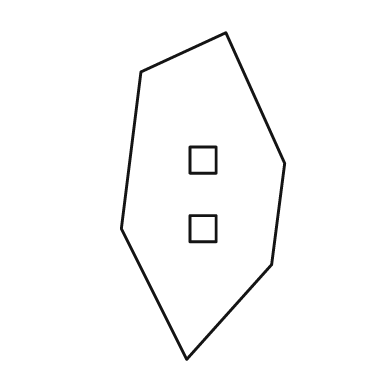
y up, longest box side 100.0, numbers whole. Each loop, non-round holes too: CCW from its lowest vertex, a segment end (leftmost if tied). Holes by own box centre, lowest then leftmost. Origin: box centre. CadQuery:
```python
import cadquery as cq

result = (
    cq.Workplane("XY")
    .moveTo(-5.0, -50.0)
    .lineTo(21.0, -21.0)
    .lineTo(25.0, 10.0)
    .lineTo(7.0, 50.0)
    .lineTo(-19.0, 38.0)
    .lineTo(-25.0, -10.0)
    .close()
    .moveTo(-4.0, -14.0)
    .lineTo(4.0, -14.0)
    .lineTo(4.0, -6.0)
    .lineTo(-4.0, -6.0)
    .close()
    .moveTo(-4.0, 7.0)
    .lineTo(4.0, 7.0)
    .lineTo(4.0, 15.0)
    .lineTo(-4.0, 15.0)
    .close()
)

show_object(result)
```